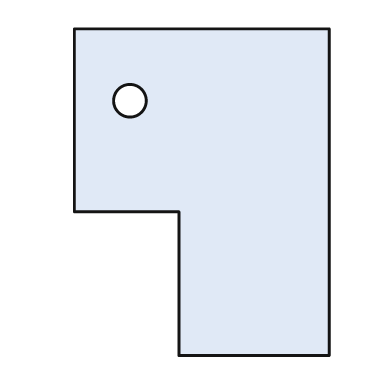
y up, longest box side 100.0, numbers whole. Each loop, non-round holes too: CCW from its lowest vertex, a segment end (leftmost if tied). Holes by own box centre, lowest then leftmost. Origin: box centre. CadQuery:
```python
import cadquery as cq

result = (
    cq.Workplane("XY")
    .moveTo(-7.0, -50.0)
    .lineTo(39.0, -50.0)
    .lineTo(39.0, 50.0)
    .lineTo(-39.0, 50.0)
    .lineTo(-39.0, -6.0)
    .lineTo(-7.0, -6.0)
    .close()
    .moveTo(-22.0, 28.0)
    .circle(5.0)
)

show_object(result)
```